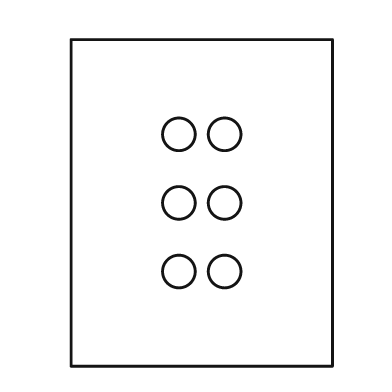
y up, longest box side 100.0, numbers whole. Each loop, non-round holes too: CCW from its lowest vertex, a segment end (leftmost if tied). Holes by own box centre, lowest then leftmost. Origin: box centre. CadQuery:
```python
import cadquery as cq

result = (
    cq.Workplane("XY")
    .moveTo(-40.0, -50.0)
    .lineTo(40.0, -50.0)
    .lineTo(40.0, 50.0)
    .lineTo(-40.0, 50.0)
    .close()
    .moveTo(-7.0, -21.0)
    .circle(5.0)
    .moveTo(7.0, -21.0)
    .circle(5.0)
    .moveTo(-7.0, 0.0)
    .circle(5.0)
    .moveTo(7.0, 0.0)
    .circle(5.0)
    .moveTo(-7.0, 21.0)
    .circle(5.0)
    .moveTo(7.0, 21.0)
    .circle(5.0)
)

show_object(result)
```